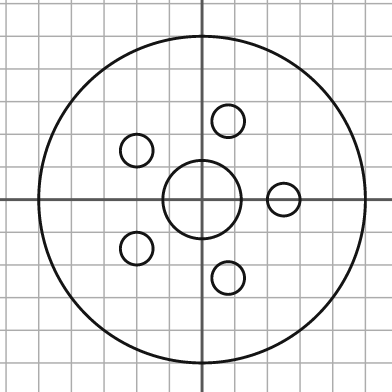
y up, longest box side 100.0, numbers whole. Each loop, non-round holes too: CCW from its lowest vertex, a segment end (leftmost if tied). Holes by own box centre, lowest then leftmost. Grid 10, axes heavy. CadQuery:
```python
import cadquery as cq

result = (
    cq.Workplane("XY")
    .moveTo(0.0, 0.0)
    .circle(50.0)
    .moveTo(8.0, -24.0)
    .circle(5.0)
    .moveTo(-20.0, -15.0)
    .circle(5.0)
    .moveTo(0.0, 0.0)
    .circle(12.0)
    .moveTo(25.0, 0.0)
    .circle(5.0)
    .moveTo(-20.0, 15.0)
    .circle(5.0)
    .moveTo(8.0, 24.0)
    .circle(5.0)
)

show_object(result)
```